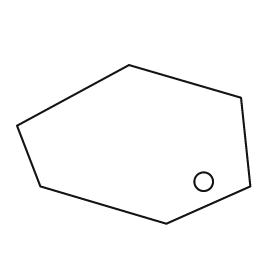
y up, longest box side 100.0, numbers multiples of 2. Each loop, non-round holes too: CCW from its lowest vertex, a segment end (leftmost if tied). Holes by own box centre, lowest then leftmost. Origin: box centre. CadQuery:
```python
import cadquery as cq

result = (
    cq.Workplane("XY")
    .moveTo(14.0, -34.0)
    .lineTo(50.0, -18.0)
    .lineTo(46.0, 20.0)
    .lineTo(-2.0, 34.0)
    .lineTo(-50.0, 8.0)
    .lineTo(-40.0, -18.0)
    .close()
    .moveTo(30.0, -16.0)
    .circle(4.0)
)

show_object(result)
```